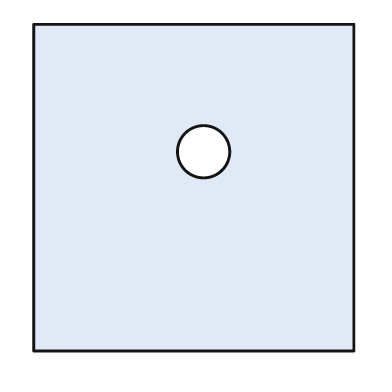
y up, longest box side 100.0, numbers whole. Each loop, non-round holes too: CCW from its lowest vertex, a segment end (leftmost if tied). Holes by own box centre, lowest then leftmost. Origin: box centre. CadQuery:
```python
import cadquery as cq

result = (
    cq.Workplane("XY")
    .moveTo(-49.0, -50.0)
    .lineTo(49.0, -50.0)
    .lineTo(49.0, 50.0)
    .lineTo(-49.0, 50.0)
    .close()
    .moveTo(3.0, 11.0)
    .circle(8.0)
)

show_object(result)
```